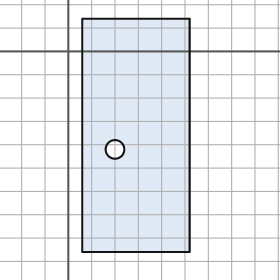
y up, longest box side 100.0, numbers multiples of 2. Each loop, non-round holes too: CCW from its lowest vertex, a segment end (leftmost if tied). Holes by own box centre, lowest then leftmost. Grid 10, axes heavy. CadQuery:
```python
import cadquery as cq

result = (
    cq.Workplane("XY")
    .moveTo(6.0, -86.0)
    .lineTo(52.0, -86.0)
    .lineTo(52.0, 14.0)
    .lineTo(6.0, 14.0)
    .close()
    .moveTo(20.0, -42.0)
    .circle(4.0)
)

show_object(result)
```